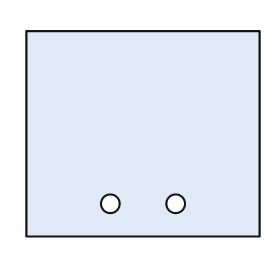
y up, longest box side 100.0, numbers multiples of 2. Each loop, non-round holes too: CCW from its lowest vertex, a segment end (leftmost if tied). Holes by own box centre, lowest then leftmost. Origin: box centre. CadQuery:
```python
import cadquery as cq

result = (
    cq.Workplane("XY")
    .moveTo(-50.0, -44.0)
    .lineTo(50.0, -44.0)
    .lineTo(50.0, 44.0)
    .lineTo(-50.0, 44.0)
    .close()
    .moveTo(-14.0, -30.0)
    .circle(4.0)
    .moveTo(14.0, -30.0)
    .circle(4.0)
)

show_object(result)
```